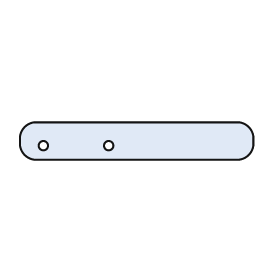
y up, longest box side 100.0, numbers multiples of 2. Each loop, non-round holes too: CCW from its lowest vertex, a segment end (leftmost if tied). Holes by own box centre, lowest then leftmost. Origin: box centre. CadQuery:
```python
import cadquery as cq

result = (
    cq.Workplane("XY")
    .moveTo(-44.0, -8.0)
    .lineTo(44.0, -8.0)
    .threePointArc((48.0, -6.0), (50.0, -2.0))
    .lineTo(50.0, 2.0)
    .threePointArc((48.0, 6.0), (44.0, 8.0))
    .lineTo(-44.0, 8.0)
    .threePointArc((-48.0, 6.0), (-50.0, 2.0))
    .lineTo(-50.0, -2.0)
    .threePointArc((-48.0, -6.0), (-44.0, -8.0))
    .close()
    .moveTo(-40.0, -2.0)
    .circle(2.0)
    .moveTo(-12.0, -2.0)
    .circle(2.0)
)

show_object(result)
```